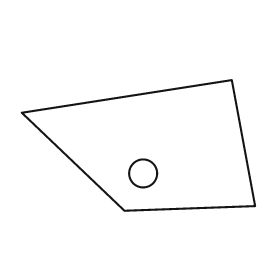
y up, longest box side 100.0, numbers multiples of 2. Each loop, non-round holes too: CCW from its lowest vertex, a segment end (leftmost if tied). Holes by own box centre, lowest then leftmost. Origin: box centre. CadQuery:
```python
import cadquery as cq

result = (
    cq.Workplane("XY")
    .moveTo(-6.0, -28.0)
    .lineTo(50.0, -26.0)
    .lineTo(40.0, 28.0)
    .lineTo(-50.0, 14.0)
    .close()
    .moveTo(2.0, -12.0)
    .circle(6.0)
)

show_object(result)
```